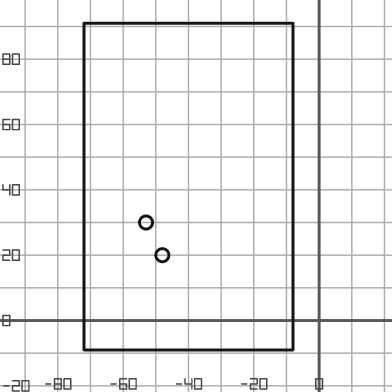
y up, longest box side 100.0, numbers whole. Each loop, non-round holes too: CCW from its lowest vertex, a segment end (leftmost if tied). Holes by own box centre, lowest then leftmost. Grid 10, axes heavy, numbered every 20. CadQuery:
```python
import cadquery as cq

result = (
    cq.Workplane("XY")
    .moveTo(-72.0, -9.0)
    .lineTo(-8.0, -9.0)
    .lineTo(-8.0, 91.0)
    .lineTo(-72.0, 91.0)
    .close()
    .moveTo(-48.0, 20.0)
    .circle(2.0)
    .moveTo(-53.0, 30.0)
    .circle(2.0)
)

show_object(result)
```